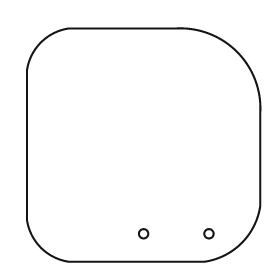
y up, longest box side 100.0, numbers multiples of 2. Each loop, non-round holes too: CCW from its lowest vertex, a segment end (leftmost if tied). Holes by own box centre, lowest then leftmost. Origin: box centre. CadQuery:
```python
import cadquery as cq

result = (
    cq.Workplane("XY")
    .moveTo(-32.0, -50.0)
    .lineTo(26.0, -50.0)
    .threePointArc((42.0, -42.0), (50.0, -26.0))
    .lineTo(50.0, 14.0)
    .threePointArc((40.0, 40.0), (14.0, 50.0))
    .lineTo(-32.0, 50.0)
    .threePointArc((-44.0, 44.0), (-50.0, 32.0))
    .lineTo(-50.0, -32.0)
    .threePointArc((-44.0, -44.0), (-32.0, -50.0))
    .close()
    .moveTo(0.0, -38.0)
    .circle(2.0)
    .moveTo(28.0, -38.0)
    .circle(2.0)
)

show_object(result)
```